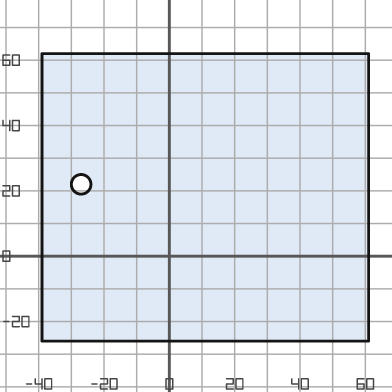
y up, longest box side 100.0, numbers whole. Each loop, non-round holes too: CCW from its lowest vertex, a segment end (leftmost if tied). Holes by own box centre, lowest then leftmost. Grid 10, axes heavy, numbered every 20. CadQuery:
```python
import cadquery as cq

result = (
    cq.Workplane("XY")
    .moveTo(-39.0, -26.0)
    .lineTo(61.0, -26.0)
    .lineTo(61.0, 62.0)
    .lineTo(-39.0, 62.0)
    .close()
    .moveTo(-27.0, 22.0)
    .circle(3.0)
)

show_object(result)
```